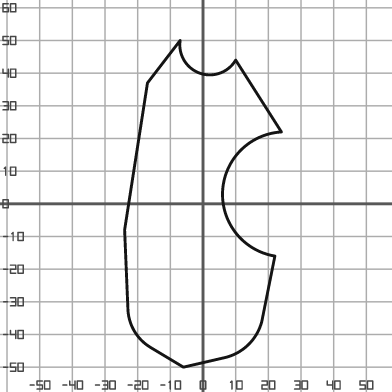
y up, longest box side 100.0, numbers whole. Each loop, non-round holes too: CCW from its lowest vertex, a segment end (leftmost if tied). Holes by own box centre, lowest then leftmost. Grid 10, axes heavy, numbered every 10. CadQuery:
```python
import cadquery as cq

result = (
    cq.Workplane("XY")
    .moveTo(-6.0, -50.0)
    .lineTo(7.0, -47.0)
    .threePointArc((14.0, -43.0), (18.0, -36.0))
    .lineTo(22.0, -16.0)
    .threePointArc((6.0, 4.0), (24.0, 22.0))
    .lineTo(10.0, 44.0)
    .threePointArc((-1.0, 40.0), (-7.0, 50.0))
    .lineTo(-17.0, 37.0)
    .lineTo(-24.0, -8.0)
    .lineTo(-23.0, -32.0)
    .threePointArc((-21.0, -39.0), (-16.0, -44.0))
    .close()
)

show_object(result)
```